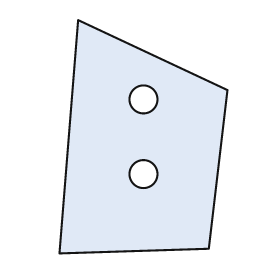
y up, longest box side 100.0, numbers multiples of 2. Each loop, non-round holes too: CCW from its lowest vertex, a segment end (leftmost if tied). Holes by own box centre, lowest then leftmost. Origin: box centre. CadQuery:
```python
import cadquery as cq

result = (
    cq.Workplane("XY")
    .moveTo(-36.0, -50.0)
    .lineTo(28.0, -48.0)
    .lineTo(36.0, 20.0)
    .lineTo(-28.0, 50.0)
    .close()
    .moveTo(0.0, -16.0)
    .circle(6.0)
    .moveTo(0.0, 16.0)
    .circle(6.0)
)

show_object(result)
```